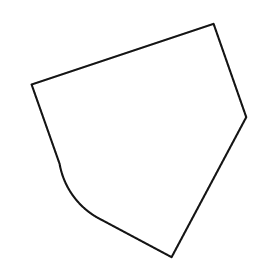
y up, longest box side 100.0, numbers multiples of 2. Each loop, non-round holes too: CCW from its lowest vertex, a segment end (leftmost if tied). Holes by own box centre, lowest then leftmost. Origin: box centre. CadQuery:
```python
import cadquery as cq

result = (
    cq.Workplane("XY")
    .moveTo(14.0, -50.0)
    .lineTo(46.0, 10.0)
    .lineTo(32.0, 50.0)
    .lineTo(-46.0, 24.0)
    .lineTo(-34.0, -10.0)
    .threePointArc((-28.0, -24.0), (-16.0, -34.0))
    .close()
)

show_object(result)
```